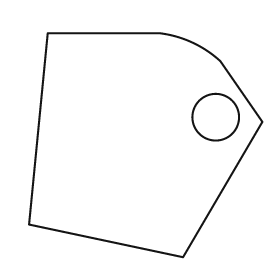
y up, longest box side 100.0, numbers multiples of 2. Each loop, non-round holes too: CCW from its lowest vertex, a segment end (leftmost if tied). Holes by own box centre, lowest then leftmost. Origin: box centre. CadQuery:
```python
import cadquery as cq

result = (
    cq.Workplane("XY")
    .moveTo(16.0, -48.0)
    .lineTo(50.0, 10.0)
    .lineTo(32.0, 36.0)
    .threePointArc((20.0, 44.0), (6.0, 48.0))
    .lineTo(-42.0, 48.0)
    .lineTo(-50.0, -34.0)
    .close()
    .moveTo(30.0, 12.0)
    .circle(10.0)
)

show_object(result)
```